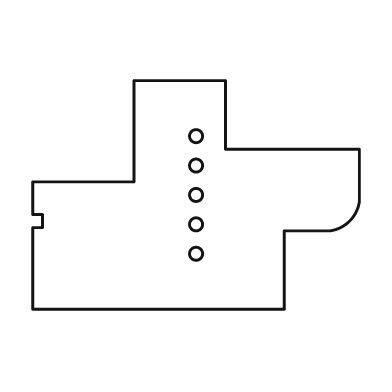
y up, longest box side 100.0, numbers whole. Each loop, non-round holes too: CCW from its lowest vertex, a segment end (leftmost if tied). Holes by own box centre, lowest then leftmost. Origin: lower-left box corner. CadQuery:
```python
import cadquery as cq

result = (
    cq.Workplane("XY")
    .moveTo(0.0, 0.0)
    .lineTo(77.0, 0.0)
    .lineTo(77.0, 24.0)
    .lineTo(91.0, 24.0)
    .threePointArc((97.0, 27.0), (100.0, 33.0))
    .lineTo(100.0, 49.0)
    .lineTo(59.0, 49.0)
    .lineTo(59.0, 70.0)
    .lineTo(31.0, 70.0)
    .lineTo(31.0, 39.0)
    .lineTo(0.0, 39.0)
    .lineTo(0.0, 29.0)
    .lineTo(3.0, 29.0)
    .lineTo(3.0, 25.0)
    .lineTo(0.0, 25.0)
    .close()
    .moveTo(50.0, 17.0)
    .circle(2.0)
    .moveTo(50.0, 26.0)
    .circle(2.0)
    .moveTo(50.0, 35.0)
    .circle(2.0)
    .moveTo(50.0, 44.0)
    .circle(2.0)
    .moveTo(50.0, 53.0)
    .circle(2.0)
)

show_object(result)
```